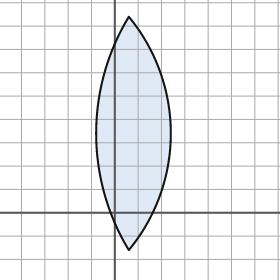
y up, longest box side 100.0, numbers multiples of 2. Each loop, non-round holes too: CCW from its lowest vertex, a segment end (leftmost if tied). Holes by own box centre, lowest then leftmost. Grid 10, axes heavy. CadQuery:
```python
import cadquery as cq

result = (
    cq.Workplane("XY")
    .moveTo(6.0, -16.0)
    .threePointArc((24.0, 34.0), (6.0, 84.0))
    .threePointArc((-8.0, 34.0), (6.0, -16.0))
    .close()
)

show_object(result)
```